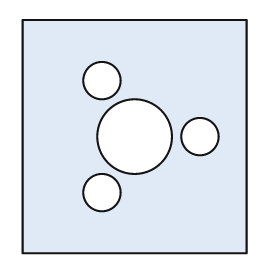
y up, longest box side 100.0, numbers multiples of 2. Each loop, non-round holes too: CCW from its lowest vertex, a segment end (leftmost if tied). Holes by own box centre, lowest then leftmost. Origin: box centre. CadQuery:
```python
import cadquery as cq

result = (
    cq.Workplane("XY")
    .moveTo(-48.0, -50.0)
    .lineTo(48.0, -50.0)
    .lineTo(48.0, 50.0)
    .lineTo(-48.0, 50.0)
    .close()
    .moveTo(-14.0, -24.0)
    .circle(8.0)
    .moveTo(0.0, 0.0)
    .circle(16.0)
    .moveTo(28.0, 0.0)
    .circle(8.0)
    .moveTo(-14.0, 24.0)
    .circle(8.0)
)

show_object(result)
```